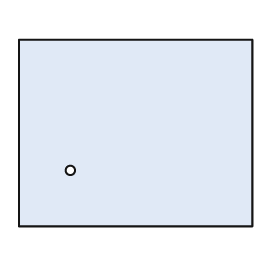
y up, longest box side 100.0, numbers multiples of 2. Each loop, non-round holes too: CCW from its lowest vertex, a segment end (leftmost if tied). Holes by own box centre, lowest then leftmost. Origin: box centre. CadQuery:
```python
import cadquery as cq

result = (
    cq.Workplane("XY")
    .moveTo(-50.0, -40.0)
    .lineTo(50.0, -40.0)
    .lineTo(50.0, 40.0)
    .lineTo(-50.0, 40.0)
    .close()
    .moveTo(-28.0, -16.0)
    .circle(2.0)
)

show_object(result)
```